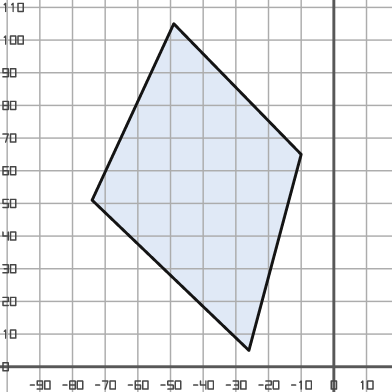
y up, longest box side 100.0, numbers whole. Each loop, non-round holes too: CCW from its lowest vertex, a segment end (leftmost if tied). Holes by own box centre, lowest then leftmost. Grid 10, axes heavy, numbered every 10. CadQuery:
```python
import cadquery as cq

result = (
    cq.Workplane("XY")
    .moveTo(-26.0, 5.0)
    .lineTo(-10.0, 65.0)
    .lineTo(-49.0, 105.0)
    .lineTo(-74.0, 51.0)
    .close()
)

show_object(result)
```